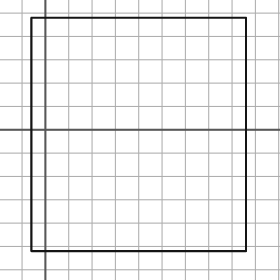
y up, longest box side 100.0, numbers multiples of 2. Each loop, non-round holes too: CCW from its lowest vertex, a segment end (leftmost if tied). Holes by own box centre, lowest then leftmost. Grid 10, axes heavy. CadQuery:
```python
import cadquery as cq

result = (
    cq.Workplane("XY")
    .moveTo(-6.0, -52.0)
    .lineTo(86.0, -52.0)
    .lineTo(86.0, 48.0)
    .lineTo(-6.0, 48.0)
    .close()
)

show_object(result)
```